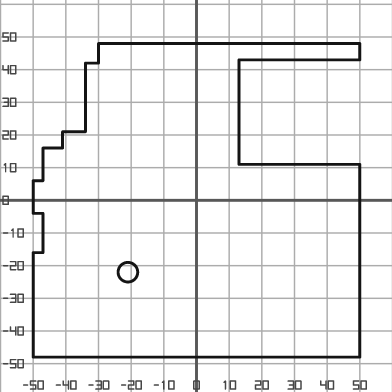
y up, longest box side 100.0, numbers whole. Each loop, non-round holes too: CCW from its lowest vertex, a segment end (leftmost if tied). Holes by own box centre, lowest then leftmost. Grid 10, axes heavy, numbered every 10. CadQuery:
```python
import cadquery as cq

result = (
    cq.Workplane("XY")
    .moveTo(-50.0, -48.0)
    .lineTo(50.0, -48.0)
    .lineTo(50.0, 11.0)
    .lineTo(13.0, 11.0)
    .lineTo(13.0, 43.0)
    .lineTo(50.0, 43.0)
    .lineTo(50.0, 48.0)
    .lineTo(-30.0, 48.0)
    .lineTo(-30.0, 42.0)
    .lineTo(-34.0, 42.0)
    .lineTo(-34.0, 21.0)
    .lineTo(-41.0, 21.0)
    .lineTo(-41.0, 16.0)
    .lineTo(-47.0, 16.0)
    .lineTo(-47.0, 6.0)
    .lineTo(-50.0, 6.0)
    .lineTo(-50.0, -4.0)
    .lineTo(-47.0, -4.0)
    .lineTo(-47.0, -16.0)
    .lineTo(-50.0, -16.0)
    .close()
    .moveTo(-21.0, -22.0)
    .circle(3.0)
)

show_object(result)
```